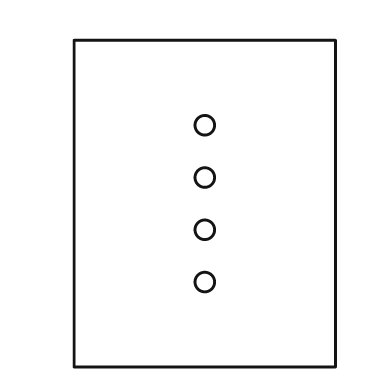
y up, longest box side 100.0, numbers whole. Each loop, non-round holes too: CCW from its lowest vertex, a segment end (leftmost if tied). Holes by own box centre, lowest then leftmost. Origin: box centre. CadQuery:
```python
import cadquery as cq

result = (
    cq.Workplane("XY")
    .moveTo(-40.0, -50.0)
    .lineTo(40.0, -50.0)
    .lineTo(40.0, 50.0)
    .lineTo(-40.0, 50.0)
    .close()
    .moveTo(0.0, -24.0)
    .circle(3.0)
    .moveTo(0.0, -8.0)
    .circle(3.0)
    .moveTo(0.0, 8.0)
    .circle(3.0)
    .moveTo(0.0, 24.0)
    .circle(3.0)
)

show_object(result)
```